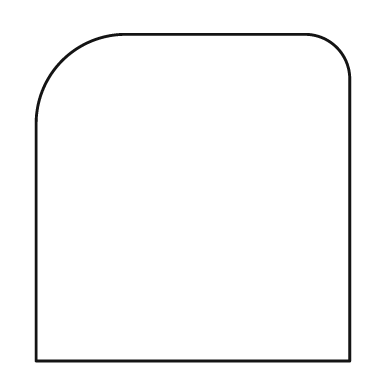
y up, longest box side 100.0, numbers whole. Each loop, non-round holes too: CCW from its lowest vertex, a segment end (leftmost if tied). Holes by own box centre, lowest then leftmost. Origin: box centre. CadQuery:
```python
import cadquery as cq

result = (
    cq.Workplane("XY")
    .moveTo(-48.0, -50.0)
    .lineTo(48.0, -50.0)
    .lineTo(48.0, 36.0)
    .threePointArc((44.0, 46.0), (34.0, 50.0))
    .lineTo(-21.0, 50.0)
    .threePointArc((-40.0, 42.0), (-48.0, 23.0))
    .close()
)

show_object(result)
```